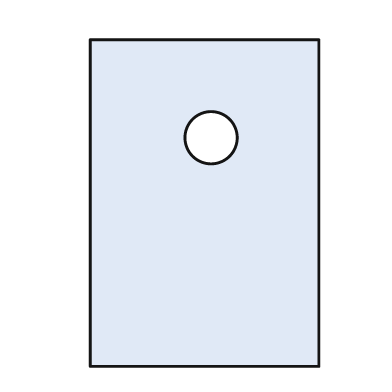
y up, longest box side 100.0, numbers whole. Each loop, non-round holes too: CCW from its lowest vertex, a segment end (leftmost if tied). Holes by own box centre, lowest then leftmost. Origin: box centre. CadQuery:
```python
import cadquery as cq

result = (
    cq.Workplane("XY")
    .moveTo(-35.0, -50.0)
    .lineTo(35.0, -50.0)
    .lineTo(35.0, 50.0)
    .lineTo(-35.0, 50.0)
    .close()
    .moveTo(2.0, 20.0)
    .circle(8.0)
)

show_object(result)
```